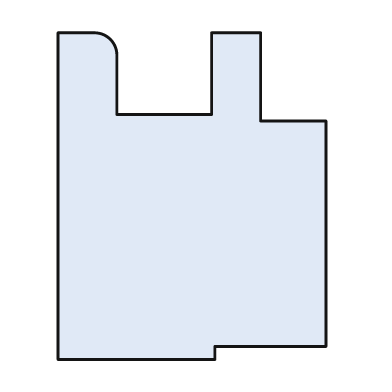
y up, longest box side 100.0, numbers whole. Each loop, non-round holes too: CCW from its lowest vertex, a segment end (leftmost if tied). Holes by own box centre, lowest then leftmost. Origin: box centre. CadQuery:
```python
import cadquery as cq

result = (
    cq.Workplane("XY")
    .moveTo(-41.0, -50.0)
    .lineTo(7.0, -50.0)
    .lineTo(7.0, -46.0)
    .lineTo(41.0, -46.0)
    .lineTo(41.0, 23.0)
    .lineTo(21.0, 23.0)
    .lineTo(21.0, 50.0)
    .lineTo(6.0, 50.0)
    .lineTo(6.0, 25.0)
    .lineTo(-23.0, 25.0)
    .lineTo(-23.0, 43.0)
    .threePointArc((-25.0, 48.0), (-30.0, 50.0))
    .lineTo(-41.0, 50.0)
    .close()
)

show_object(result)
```